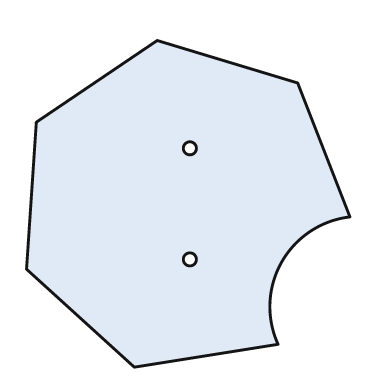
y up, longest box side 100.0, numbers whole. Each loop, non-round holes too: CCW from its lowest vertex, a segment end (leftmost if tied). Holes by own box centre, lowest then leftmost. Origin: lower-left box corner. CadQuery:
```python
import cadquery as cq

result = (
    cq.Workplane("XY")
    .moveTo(33.0, 0.0)
    .lineTo(77.0, 7.0)
    .threePointArc((78.0, 32.0), (99.0, 46.0))
    .lineTo(83.0, 87.0)
    .lineTo(40.0, 100.0)
    .lineTo(3.0, 75.0)
    .lineTo(0.0, 30.0)
    .close()
    .moveTo(50.0, 33.0)
    .circle(2.0)
    .moveTo(50.0, 67.0)
    .circle(2.0)
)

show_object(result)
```